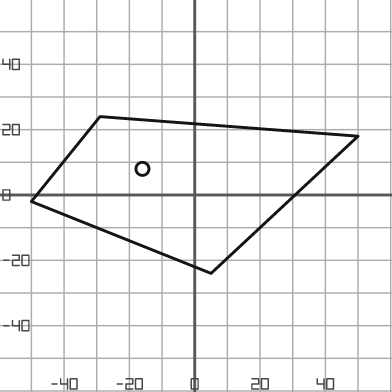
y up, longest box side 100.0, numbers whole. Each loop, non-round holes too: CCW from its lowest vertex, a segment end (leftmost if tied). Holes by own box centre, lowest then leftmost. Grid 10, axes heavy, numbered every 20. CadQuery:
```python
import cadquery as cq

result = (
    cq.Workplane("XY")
    .moveTo(5.0, -24.0)
    .lineTo(50.0, 18.0)
    .lineTo(-29.0, 24.0)
    .lineTo(-50.0, -2.0)
    .close()
    .moveTo(-16.0, 8.0)
    .circle(2.0)
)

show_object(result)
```